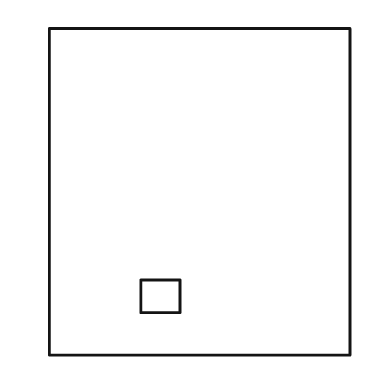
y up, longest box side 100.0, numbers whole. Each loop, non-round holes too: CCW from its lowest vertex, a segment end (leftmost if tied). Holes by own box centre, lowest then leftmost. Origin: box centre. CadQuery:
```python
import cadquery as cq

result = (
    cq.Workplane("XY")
    .moveTo(-46.0, -50.0)
    .lineTo(46.0, -50.0)
    .lineTo(46.0, 50.0)
    .lineTo(-46.0, 50.0)
    .close()
    .moveTo(-18.0, -37.0)
    .lineTo(-6.0, -37.0)
    .lineTo(-6.0, -27.0)
    .lineTo(-18.0, -27.0)
    .close()
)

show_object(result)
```